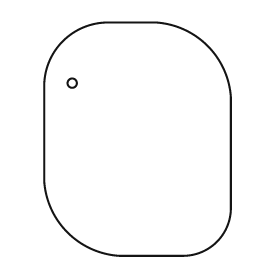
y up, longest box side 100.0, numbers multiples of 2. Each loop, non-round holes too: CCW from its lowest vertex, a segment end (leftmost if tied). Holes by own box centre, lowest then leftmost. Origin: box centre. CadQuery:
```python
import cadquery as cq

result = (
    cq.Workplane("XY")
    .moveTo(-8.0, -50.0)
    .lineTo(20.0, -50.0)
    .threePointArc((34.0, -44.0), (40.0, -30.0))
    .lineTo(40.0, 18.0)
    .threePointArc((30.0, 40.0), (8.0, 50.0))
    .lineTo(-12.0, 50.0)
    .threePointArc((-32.0, 42.0), (-40.0, 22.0))
    .lineTo(-40.0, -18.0)
    .threePointArc((-30.0, -40.0), (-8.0, -50.0))
    .close()
    .moveTo(-28.0, 24.0)
    .circle(2.0)
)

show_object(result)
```